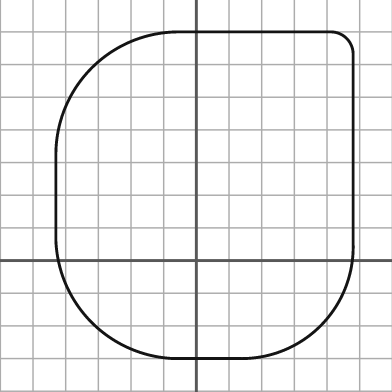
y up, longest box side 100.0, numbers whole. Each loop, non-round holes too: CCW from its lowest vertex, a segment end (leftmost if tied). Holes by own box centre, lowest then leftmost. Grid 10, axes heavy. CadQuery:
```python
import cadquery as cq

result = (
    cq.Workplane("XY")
    .moveTo(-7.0, -30.0)
    .lineTo(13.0, -30.0)
    .threePointArc((38.0, -20.0), (48.0, 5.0))
    .lineTo(48.0, 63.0)
    .threePointArc((46.0, 68.0), (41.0, 70.0))
    .lineTo(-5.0, 70.0)
    .threePointArc((-32.0, 59.0), (-43.0, 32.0))
    .lineTo(-43.0, 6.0)
    .threePointArc((-32.0, -19.0), (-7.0, -30.0))
    .close()
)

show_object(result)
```